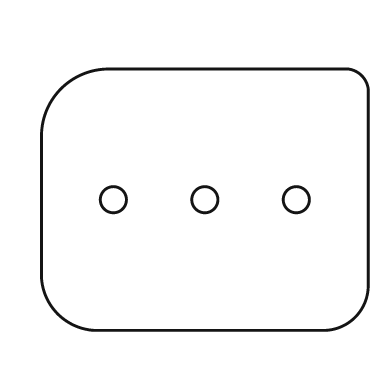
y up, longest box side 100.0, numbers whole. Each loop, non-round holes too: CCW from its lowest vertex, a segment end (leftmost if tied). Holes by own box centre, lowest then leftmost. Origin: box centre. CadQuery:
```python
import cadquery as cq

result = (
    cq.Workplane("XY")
    .moveTo(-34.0, -40.0)
    .lineTo(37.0, -40.0)
    .threePointArc((46.0, -36.0), (50.0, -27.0))
    .lineTo(50.0, 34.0)
    .threePointArc((48.0, 38.0), (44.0, 40.0))
    .lineTo(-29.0, 40.0)
    .threePointArc((-44.0, 34.0), (-50.0, 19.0))
    .lineTo(-50.0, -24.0)
    .threePointArc((-45.0, -35.0), (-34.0, -40.0))
    .close()
    .moveTo(-28.0, 0.0)
    .circle(4.0)
    .moveTo(0.0, 0.0)
    .circle(4.0)
    .moveTo(28.0, 0.0)
    .circle(4.0)
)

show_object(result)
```